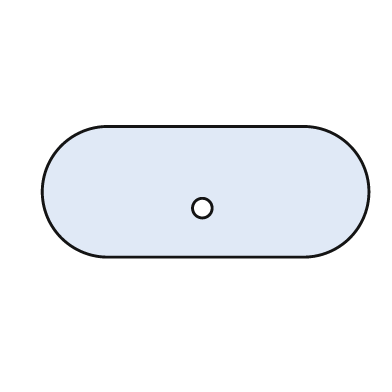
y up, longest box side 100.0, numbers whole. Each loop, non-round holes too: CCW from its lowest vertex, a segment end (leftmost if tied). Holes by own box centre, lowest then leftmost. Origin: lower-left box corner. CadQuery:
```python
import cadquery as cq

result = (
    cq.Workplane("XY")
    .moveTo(20.0, 0.0)
    .lineTo(80.0, 0.0)
    .threePointArc((100.0, 20.0), (80.0, 40.0))
    .lineTo(20.0, 40.0)
    .threePointArc((0.0, 20.0), (20.0, 0.0))
    .close()
    .moveTo(49.0, 15.0)
    .circle(3.0)
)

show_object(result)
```